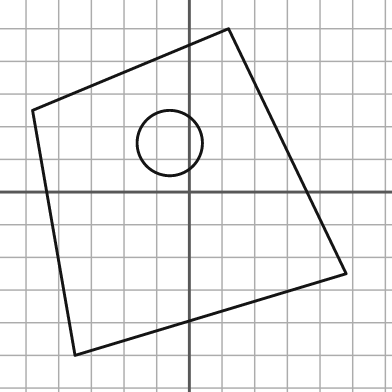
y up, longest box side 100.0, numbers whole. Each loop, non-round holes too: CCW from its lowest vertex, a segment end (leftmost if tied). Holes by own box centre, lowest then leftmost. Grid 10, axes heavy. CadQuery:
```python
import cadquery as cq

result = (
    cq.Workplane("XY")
    .moveTo(-35.0, -50.0)
    .lineTo(48.0, -25.0)
    .lineTo(12.0, 50.0)
    .lineTo(-48.0, 25.0)
    .close()
    .moveTo(-6.0, 15.0)
    .circle(10.0)
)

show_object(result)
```